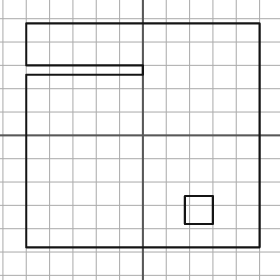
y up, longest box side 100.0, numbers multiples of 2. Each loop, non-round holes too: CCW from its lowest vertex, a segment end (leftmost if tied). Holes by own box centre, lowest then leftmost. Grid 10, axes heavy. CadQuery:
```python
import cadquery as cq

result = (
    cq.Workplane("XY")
    .moveTo(-50.0, -48.0)
    .lineTo(50.0, -48.0)
    .lineTo(50.0, 48.0)
    .lineTo(-50.0, 48.0)
    .lineTo(-50.0, 30.0)
    .lineTo(0.0, 30.0)
    .lineTo(0.0, 26.0)
    .lineTo(-50.0, 26.0)
    .close()
    .moveTo(18.0, -38.0)
    .lineTo(30.0, -38.0)
    .lineTo(30.0, -26.0)
    .lineTo(18.0, -26.0)
    .close()
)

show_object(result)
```